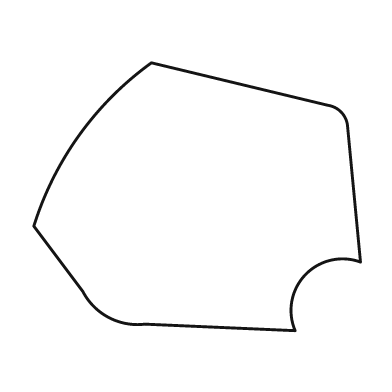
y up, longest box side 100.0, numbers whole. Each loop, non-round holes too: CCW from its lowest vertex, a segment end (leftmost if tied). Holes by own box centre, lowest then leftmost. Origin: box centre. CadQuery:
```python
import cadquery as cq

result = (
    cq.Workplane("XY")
    .moveTo(30.0, -41.0)
    .threePointArc((33.0, -24.0), (50.0, -20.0))
    .lineTo(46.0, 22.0)
    .threePointArc((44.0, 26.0), (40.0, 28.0))
    .lineTo(-14.0, 41.0)
    .threePointArc((-36.0, 19.0), (-50.0, -9.0))
    .lineTo(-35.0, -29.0)
    .threePointArc((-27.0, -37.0), (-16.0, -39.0))
    .close()
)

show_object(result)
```